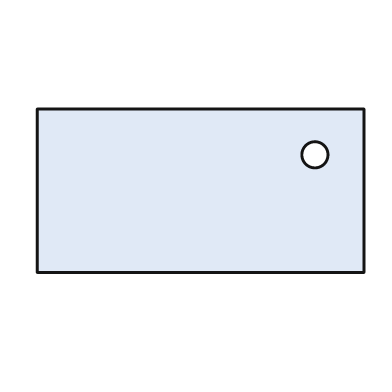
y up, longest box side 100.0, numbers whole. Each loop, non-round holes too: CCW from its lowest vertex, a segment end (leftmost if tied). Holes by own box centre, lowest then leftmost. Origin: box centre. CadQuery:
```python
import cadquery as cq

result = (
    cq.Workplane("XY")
    .moveTo(-50.0, -25.0)
    .lineTo(50.0, -25.0)
    .lineTo(50.0, 25.0)
    .lineTo(-50.0, 25.0)
    .close()
    .moveTo(35.0, 11.0)
    .circle(4.0)
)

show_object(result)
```